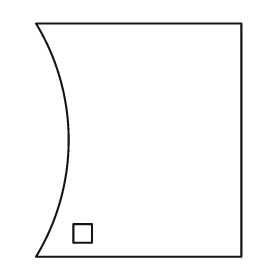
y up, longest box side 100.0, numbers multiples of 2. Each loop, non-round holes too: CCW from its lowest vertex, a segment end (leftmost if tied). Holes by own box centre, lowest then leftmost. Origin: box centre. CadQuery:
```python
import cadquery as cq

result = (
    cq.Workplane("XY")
    .moveTo(-44.0, -50.0)
    .lineTo(44.0, -50.0)
    .lineTo(44.0, 50.0)
    .lineTo(-44.0, 50.0)
    .threePointArc((-30.0, 0.0), (-44.0, -50.0))
    .close()
    .moveTo(-28.0, -44.0)
    .lineTo(-20.0, -44.0)
    .lineTo(-20.0, -36.0)
    .lineTo(-28.0, -36.0)
    .close()
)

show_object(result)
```